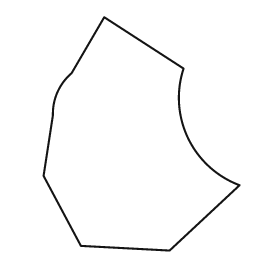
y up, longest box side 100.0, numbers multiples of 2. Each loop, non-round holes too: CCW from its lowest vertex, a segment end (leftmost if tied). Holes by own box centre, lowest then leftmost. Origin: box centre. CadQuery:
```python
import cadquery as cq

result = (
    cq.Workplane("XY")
    .moveTo(12.0, -50.0)
    .lineTo(42.0, -22.0)
    .threePointArc((20.0, -2.0), (18.0, 28.0))
    .lineTo(-16.0, 50.0)
    .lineTo(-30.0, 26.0)
    .threePointArc((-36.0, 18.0), (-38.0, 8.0))
    .lineTo(-42.0, -18.0)
    .lineTo(-26.0, -48.0)
    .close()
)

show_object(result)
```